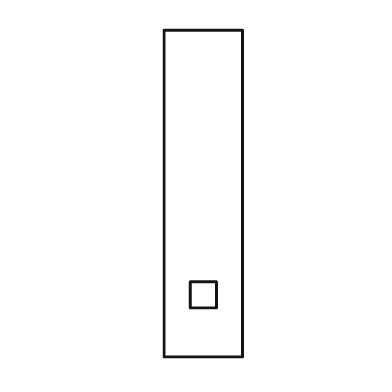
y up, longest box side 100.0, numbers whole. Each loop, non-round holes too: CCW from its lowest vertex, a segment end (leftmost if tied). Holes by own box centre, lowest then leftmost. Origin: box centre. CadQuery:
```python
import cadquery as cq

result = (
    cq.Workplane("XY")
    .moveTo(-12.0, -50.0)
    .lineTo(12.0, -50.0)
    .lineTo(12.0, 50.0)
    .lineTo(-12.0, 50.0)
    .close()
    .moveTo(-4.0, -35.0)
    .lineTo(4.0, -35.0)
    .lineTo(4.0, -27.0)
    .lineTo(-4.0, -27.0)
    .close()
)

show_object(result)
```